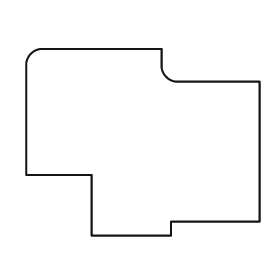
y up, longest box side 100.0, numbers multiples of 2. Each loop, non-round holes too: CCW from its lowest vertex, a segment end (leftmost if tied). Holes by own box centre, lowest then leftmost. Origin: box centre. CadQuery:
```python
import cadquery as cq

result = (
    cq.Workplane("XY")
    .moveTo(-22.0, -40.0)
    .lineTo(12.0, -40.0)
    .lineTo(12.0, -34.0)
    .lineTo(50.0, -34.0)
    .lineTo(50.0, 26.0)
    .lineTo(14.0, 26.0)
    .threePointArc((10.0, 28.0), (8.0, 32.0))
    .lineTo(8.0, 40.0)
    .lineTo(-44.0, 40.0)
    .threePointArc((-48.0, 38.0), (-50.0, 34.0))
    .lineTo(-50.0, -14.0)
    .lineTo(-22.0, -14.0)
    .close()
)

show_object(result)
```